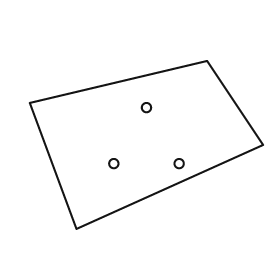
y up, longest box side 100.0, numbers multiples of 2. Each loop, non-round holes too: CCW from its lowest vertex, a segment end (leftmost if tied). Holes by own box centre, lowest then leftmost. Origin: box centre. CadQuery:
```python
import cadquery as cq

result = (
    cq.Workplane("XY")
    .moveTo(-30.0, -36.0)
    .lineTo(50.0, 0.0)
    .lineTo(26.0, 36.0)
    .lineTo(-50.0, 18.0)
    .close()
    .moveTo(-14.0, -8.0)
    .circle(2.0)
    .moveTo(14.0, -8.0)
    .circle(2.0)
    .moveTo(0.0, 16.0)
    .circle(2.0)
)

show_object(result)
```